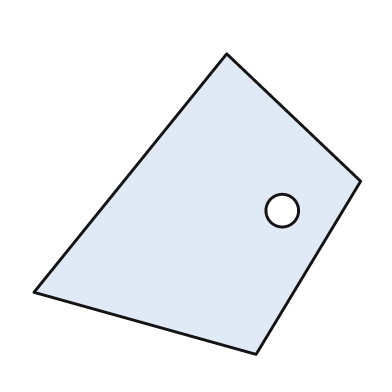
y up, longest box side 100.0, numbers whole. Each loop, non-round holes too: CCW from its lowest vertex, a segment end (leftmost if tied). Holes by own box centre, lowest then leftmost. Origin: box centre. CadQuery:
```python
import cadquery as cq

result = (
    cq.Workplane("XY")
    .moveTo(18.0, -46.0)
    .lineTo(50.0, 7.0)
    .lineTo(9.0, 46.0)
    .lineTo(-50.0, -27.0)
    .close()
    .moveTo(26.0, -2.0)
    .circle(5.0)
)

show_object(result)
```